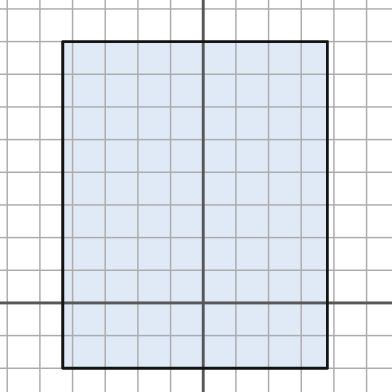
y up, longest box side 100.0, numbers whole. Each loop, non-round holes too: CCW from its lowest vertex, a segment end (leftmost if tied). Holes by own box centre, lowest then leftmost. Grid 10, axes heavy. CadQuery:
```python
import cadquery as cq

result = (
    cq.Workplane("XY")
    .moveTo(-43.0, -20.0)
    .lineTo(38.0, -20.0)
    .lineTo(38.0, 80.0)
    .lineTo(-43.0, 80.0)
    .close()
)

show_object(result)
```